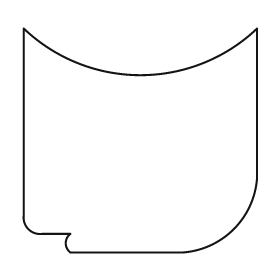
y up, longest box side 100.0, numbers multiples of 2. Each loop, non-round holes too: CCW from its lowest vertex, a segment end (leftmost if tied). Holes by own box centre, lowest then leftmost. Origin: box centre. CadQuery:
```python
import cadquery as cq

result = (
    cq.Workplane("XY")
    .moveTo(-30.0, -48.0)
    .lineTo(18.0, -48.0)
    .threePointArc((40.0, -38.0), (50.0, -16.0))
    .lineTo(50.0, 48.0)
    .threePointArc((0.0, 28.0), (-50.0, 48.0))
    .lineTo(-50.0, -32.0)
    .threePointArc((-48.0, -38.0), (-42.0, -40.0))
    .lineTo(-30.0, -40.0)
    .threePointArc((-32.0, -44.0), (-30.0, -48.0))
    .close()
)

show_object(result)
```